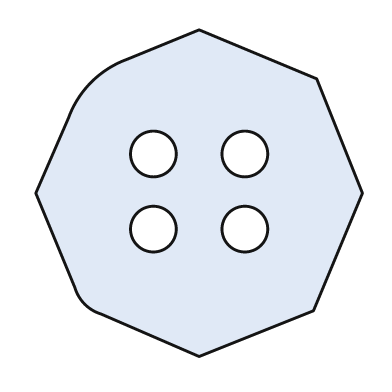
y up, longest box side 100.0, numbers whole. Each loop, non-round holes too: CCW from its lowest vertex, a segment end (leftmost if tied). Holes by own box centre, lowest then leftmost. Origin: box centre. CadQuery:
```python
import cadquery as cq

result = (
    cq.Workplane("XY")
    .moveTo(0.0, -50.0)
    .lineTo(35.0, -36.0)
    .lineTo(50.0, 0.0)
    .lineTo(36.0, 35.0)
    .lineTo(0.0, 50.0)
    .lineTo(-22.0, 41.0)
    .threePointArc((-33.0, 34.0), (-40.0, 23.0))
    .lineTo(-50.0, 0.0)
    .lineTo(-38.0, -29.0)
    .threePointArc((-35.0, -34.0), (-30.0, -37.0))
    .close()
    .moveTo(-14.0, -11.0)
    .circle(7.0)
    .moveTo(14.0, -11.0)
    .circle(7.0)
    .moveTo(-14.0, 12.0)
    .circle(7.0)
    .moveTo(14.0, 12.0)
    .circle(7.0)
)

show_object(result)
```